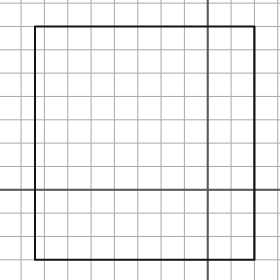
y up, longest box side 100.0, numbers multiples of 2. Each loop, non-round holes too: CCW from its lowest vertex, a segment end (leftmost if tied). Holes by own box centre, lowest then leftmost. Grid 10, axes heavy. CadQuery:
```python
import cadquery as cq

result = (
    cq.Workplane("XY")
    .moveTo(-74.0, -30.0)
    .lineTo(20.0, -30.0)
    .lineTo(20.0, 70.0)
    .lineTo(-74.0, 70.0)
    .close()
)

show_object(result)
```